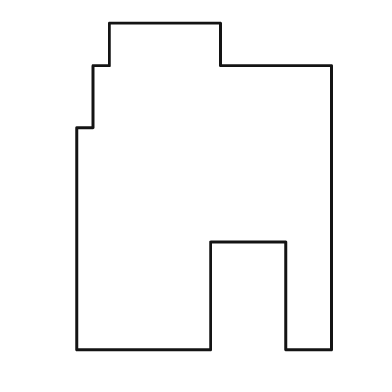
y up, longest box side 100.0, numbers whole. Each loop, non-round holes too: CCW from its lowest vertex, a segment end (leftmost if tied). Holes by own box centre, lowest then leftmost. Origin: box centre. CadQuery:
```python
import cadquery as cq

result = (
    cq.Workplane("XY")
    .moveTo(-39.0, -50.0)
    .lineTo(2.0, -50.0)
    .lineTo(2.0, -17.0)
    .lineTo(25.0, -17.0)
    .lineTo(25.0, -50.0)
    .lineTo(39.0, -50.0)
    .lineTo(39.0, 37.0)
    .lineTo(5.0, 37.0)
    .lineTo(5.0, 50.0)
    .lineTo(-29.0, 50.0)
    .lineTo(-29.0, 37.0)
    .lineTo(-34.0, 37.0)
    .lineTo(-34.0, 18.0)
    .lineTo(-39.0, 18.0)
    .close()
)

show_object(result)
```